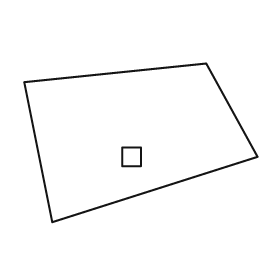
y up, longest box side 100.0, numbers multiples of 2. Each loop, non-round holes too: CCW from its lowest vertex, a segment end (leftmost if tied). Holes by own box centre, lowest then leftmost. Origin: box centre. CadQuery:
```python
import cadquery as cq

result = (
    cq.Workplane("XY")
    .moveTo(-38.0, -34.0)
    .lineTo(50.0, -6.0)
    .lineTo(28.0, 34.0)
    .lineTo(-50.0, 26.0)
    .close()
    .moveTo(-8.0, -10.0)
    .lineTo(0.0, -10.0)
    .lineTo(0.0, -2.0)
    .lineTo(-8.0, -2.0)
    .close()
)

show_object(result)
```